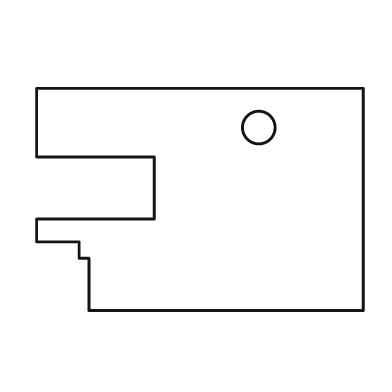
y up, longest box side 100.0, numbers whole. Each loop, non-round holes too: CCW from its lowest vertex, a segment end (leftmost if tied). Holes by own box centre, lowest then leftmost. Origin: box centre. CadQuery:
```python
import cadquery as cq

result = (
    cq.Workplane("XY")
    .moveTo(-34.0, -34.0)
    .lineTo(50.0, -34.0)
    .lineTo(50.0, 34.0)
    .lineTo(-50.0, 34.0)
    .lineTo(-50.0, 13.0)
    .lineTo(-14.0, 13.0)
    .lineTo(-14.0, -6.0)
    .lineTo(-50.0, -6.0)
    .lineTo(-50.0, -13.0)
    .lineTo(-37.0, -13.0)
    .lineTo(-37.0, -18.0)
    .lineTo(-34.0, -18.0)
    .close()
    .moveTo(18.0, 22.0)
    .circle(5.0)
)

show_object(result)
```